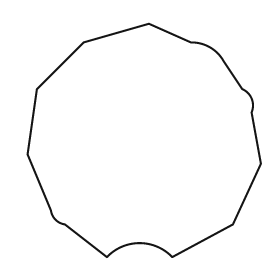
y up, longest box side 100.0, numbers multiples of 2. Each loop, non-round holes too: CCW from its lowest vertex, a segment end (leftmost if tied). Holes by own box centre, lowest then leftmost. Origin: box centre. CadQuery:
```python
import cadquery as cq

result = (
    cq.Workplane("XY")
    .moveTo(-16.0, -50.0)
    .threePointArc((-2.0, -44.0), (12.0, -50.0))
    .lineTo(38.0, -36.0)
    .lineTo(50.0, -10.0)
    .lineTo(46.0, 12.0)
    .threePointArc((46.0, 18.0), (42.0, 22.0))
    .lineTo(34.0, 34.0)
    .threePointArc((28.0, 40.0), (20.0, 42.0))
    .lineTo(2.0, 50.0)
    .lineTo(-26.0, 42.0)
    .lineTo(-46.0, 22.0)
    .lineTo(-50.0, -6.0)
    .lineTo(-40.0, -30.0)
    .threePointArc((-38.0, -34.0), (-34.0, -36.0))
    .close()
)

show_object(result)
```